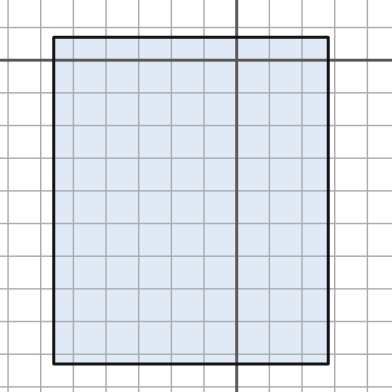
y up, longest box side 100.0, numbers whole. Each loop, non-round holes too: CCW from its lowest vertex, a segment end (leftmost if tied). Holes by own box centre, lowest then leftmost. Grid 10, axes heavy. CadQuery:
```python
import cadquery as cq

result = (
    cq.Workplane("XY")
    .moveTo(-56.0, -93.0)
    .lineTo(28.0, -93.0)
    .lineTo(28.0, 7.0)
    .lineTo(-56.0, 7.0)
    .close()
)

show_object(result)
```